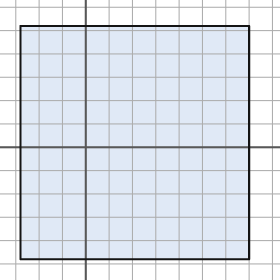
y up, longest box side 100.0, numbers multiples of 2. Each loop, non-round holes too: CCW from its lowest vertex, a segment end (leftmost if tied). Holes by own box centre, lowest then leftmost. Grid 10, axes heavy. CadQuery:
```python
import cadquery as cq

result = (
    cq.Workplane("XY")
    .moveTo(-28.0, -48.0)
    .lineTo(70.0, -48.0)
    .lineTo(70.0, 52.0)
    .lineTo(-28.0, 52.0)
    .close()
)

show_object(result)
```